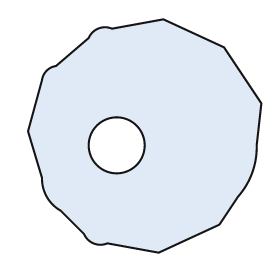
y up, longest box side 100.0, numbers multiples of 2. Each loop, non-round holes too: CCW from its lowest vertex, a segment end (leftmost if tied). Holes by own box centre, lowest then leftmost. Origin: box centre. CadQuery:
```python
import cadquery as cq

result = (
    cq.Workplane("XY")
    .moveTo(6.0, -50.0)
    .lineTo(32.0, -38.0)
    .lineTo(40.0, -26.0)
    .threePointArc((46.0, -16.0), (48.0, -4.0))
    .lineTo(50.0, 14.0)
    .lineTo(34.0, 38.0)
    .lineTo(8.0, 50.0)
    .lineTo(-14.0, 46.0)
    .threePointArc((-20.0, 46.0), (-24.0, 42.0))
    .lineTo(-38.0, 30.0)
    .threePointArc((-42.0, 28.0), (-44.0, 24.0))
    .lineTo(-50.0, 2.0)
    .lineTo(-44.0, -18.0)
    .threePointArc((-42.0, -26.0), (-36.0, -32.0))
    .lineTo(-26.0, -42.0)
    .threePointArc((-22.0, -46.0), (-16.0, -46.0))
    .close()
    .moveTo(-12.0, -4.0)
    .circle(12.0)
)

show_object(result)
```